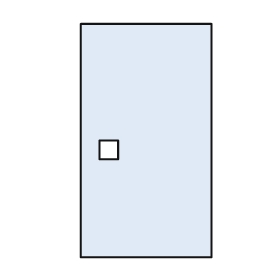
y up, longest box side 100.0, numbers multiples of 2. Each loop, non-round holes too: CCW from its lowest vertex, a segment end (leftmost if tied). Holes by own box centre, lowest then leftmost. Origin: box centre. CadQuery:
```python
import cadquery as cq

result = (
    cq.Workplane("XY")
    .moveTo(-28.0, -50.0)
    .lineTo(28.0, -50.0)
    .lineTo(28.0, 50.0)
    .lineTo(-28.0, 50.0)
    .close()
    .moveTo(-20.0, -8.0)
    .lineTo(-12.0, -8.0)
    .lineTo(-12.0, 0.0)
    .lineTo(-20.0, 0.0)
    .close()
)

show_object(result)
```